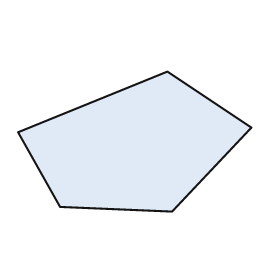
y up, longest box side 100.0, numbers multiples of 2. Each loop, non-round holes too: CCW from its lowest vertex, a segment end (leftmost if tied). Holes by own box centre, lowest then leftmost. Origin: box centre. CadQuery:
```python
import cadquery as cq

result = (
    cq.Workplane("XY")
    .moveTo(16.0, -30.0)
    .lineTo(50.0, 6.0)
    .lineTo(14.0, 30.0)
    .lineTo(-50.0, 4.0)
    .lineTo(-32.0, -28.0)
    .close()
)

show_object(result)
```